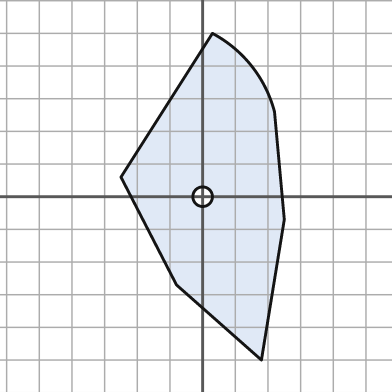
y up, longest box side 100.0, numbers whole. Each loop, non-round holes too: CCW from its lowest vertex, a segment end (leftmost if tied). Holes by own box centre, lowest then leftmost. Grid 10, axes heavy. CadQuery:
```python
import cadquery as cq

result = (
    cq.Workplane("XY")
    .moveTo(18.0, -50.0)
    .lineTo(25.0, -7.0)
    .lineTo(22.0, 26.0)
    .threePointArc((15.0, 40.0), (3.0, 50.0))
    .lineTo(-25.0, 6.0)
    .lineTo(-8.0, -27.0)
    .close()
    .moveTo(0.0, 0.0)
    .circle(3.0)
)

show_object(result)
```